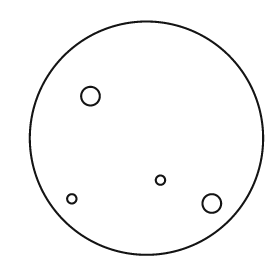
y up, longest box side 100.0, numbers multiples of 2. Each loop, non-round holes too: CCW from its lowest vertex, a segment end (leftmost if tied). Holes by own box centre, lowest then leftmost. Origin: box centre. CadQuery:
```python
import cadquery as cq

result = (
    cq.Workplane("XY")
    .moveTo(0.0, 0.0)
    .circle(50.0)
    .moveTo(28.0, -28.0)
    .circle(4.0)
    .moveTo(-32.0, -26.0)
    .circle(2.0)
    .moveTo(6.0, -18.0)
    .circle(2.0)
    .moveTo(-24.0, 18.0)
    .circle(4.0)
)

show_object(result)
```